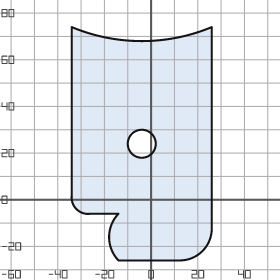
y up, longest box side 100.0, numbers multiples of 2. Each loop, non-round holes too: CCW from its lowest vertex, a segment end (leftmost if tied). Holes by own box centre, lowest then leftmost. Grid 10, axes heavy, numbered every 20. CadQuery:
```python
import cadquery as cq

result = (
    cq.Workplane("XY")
    .moveTo(-14.0, -26.0)
    .lineTo(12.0, -26.0)
    .threePointArc((22.0, -22.0), (26.0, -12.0))
    .lineTo(26.0, 74.0)
    .threePointArc((-4.0, 68.0), (-34.0, 74.0))
    .lineTo(-34.0, 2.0)
    .threePointArc((-32.0, -4.0), (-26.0, -6.0))
    .lineTo(-14.0, -6.0)
    .threePointArc((-18.0, -16.0), (-14.0, -26.0))
    .close()
    .moveTo(-4.0, 24.0)
    .circle(6.0)
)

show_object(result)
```